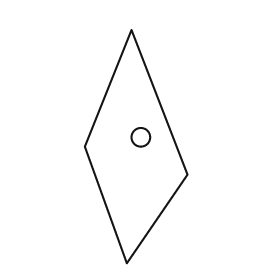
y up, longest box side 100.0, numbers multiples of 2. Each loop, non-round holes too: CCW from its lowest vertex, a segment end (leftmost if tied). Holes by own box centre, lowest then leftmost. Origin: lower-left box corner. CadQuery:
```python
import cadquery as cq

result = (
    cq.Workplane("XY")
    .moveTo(18.0, 0.0)
    .lineTo(44.0, 38.0)
    .lineTo(20.0, 100.0)
    .lineTo(0.0, 50.0)
    .close()
    .moveTo(24.0, 54.0)
    .circle(4.0)
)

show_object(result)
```